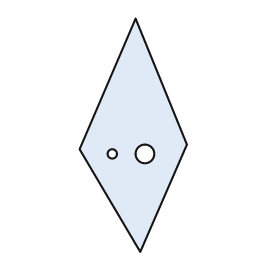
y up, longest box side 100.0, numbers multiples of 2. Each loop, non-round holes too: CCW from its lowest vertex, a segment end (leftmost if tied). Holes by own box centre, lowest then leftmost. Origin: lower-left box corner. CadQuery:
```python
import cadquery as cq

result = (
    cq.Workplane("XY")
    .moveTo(26.0, 0.0)
    .lineTo(46.0, 46.0)
    .lineTo(24.0, 100.0)
    .lineTo(0.0, 44.0)
    .close()
    .moveTo(14.0, 42.0)
    .circle(2.0)
    .moveTo(28.0, 42.0)
    .circle(4.0)
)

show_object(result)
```